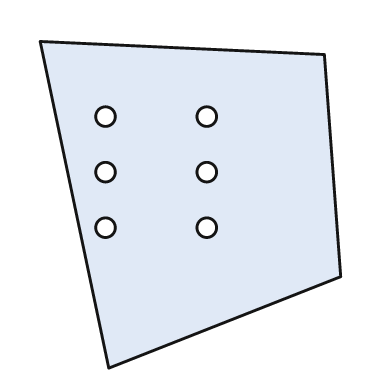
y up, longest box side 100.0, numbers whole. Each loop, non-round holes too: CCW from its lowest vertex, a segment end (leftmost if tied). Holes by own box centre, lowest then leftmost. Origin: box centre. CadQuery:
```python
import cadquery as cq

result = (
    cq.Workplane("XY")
    .moveTo(-25.0, -50.0)
    .lineTo(46.0, -22.0)
    .lineTo(41.0, 46.0)
    .lineTo(-46.0, 50.0)
    .close()
    .moveTo(-26.0, -7.0)
    .circle(3.0)
    .moveTo(5.0, -7.0)
    .circle(3.0)
    .moveTo(-26.0, 10.0)
    .circle(3.0)
    .moveTo(5.0, 10.0)
    .circle(3.0)
    .moveTo(-26.0, 27.0)
    .circle(3.0)
    .moveTo(5.0, 27.0)
    .circle(3.0)
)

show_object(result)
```